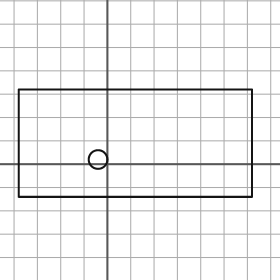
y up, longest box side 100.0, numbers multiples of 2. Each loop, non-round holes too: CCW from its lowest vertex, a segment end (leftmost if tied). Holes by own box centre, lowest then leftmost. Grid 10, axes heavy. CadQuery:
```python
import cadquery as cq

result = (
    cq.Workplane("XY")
    .moveTo(-38.0, -14.0)
    .lineTo(62.0, -14.0)
    .lineTo(62.0, 32.0)
    .lineTo(-38.0, 32.0)
    .close()
    .moveTo(-4.0, 2.0)
    .circle(4.0)
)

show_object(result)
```